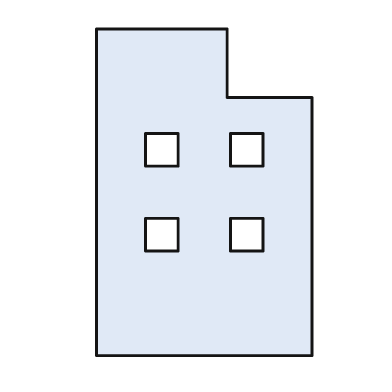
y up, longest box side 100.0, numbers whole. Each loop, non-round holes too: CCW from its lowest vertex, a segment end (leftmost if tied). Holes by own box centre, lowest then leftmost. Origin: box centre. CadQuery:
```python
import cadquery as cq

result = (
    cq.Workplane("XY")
    .moveTo(-33.0, -50.0)
    .lineTo(33.0, -50.0)
    .lineTo(33.0, 29.0)
    .lineTo(7.0, 29.0)
    .lineTo(7.0, 50.0)
    .lineTo(-33.0, 50.0)
    .close()
    .moveTo(-18.0, -18.0)
    .lineTo(-8.0, -18.0)
    .lineTo(-8.0, -8.0)
    .lineTo(-18.0, -8.0)
    .close()
    .moveTo(8.0, -18.0)
    .lineTo(18.0, -18.0)
    .lineTo(18.0, -8.0)
    .lineTo(8.0, -8.0)
    .close()
    .moveTo(-18.0, 8.0)
    .lineTo(-8.0, 8.0)
    .lineTo(-8.0, 18.0)
    .lineTo(-18.0, 18.0)
    .close()
    .moveTo(8.0, 8.0)
    .lineTo(18.0, 8.0)
    .lineTo(18.0, 18.0)
    .lineTo(8.0, 18.0)
    .close()
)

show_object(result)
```